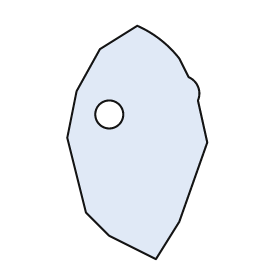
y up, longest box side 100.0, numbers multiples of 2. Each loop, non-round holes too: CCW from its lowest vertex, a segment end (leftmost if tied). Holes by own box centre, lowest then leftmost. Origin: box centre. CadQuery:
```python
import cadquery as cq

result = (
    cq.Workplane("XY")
    .moveTo(8.0, -50.0)
    .lineTo(18.0, -34.0)
    .lineTo(30.0, 0.0)
    .lineTo(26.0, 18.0)
    .threePointArc((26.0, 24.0), (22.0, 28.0))
    .lineTo(18.0, 36.0)
    .threePointArc((10.0, 44.0), (0.0, 50.0))
    .lineTo(-16.0, 40.0)
    .lineTo(-26.0, 22.0)
    .lineTo(-30.0, 2.0)
    .lineTo(-22.0, -30.0)
    .lineTo(-12.0, -40.0)
    .close()
    .moveTo(-12.0, 12.0)
    .circle(6.0)
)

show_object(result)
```